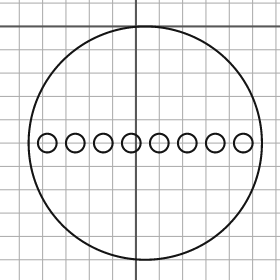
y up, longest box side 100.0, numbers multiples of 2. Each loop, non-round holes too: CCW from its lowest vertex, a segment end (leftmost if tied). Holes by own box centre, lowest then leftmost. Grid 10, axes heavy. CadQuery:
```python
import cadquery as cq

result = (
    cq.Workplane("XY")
    .moveTo(4.0, -50.0)
    .circle(50.0)
    .moveTo(-38.0, -50.0)
    .circle(4.0)
    .moveTo(-26.0, -50.0)
    .circle(4.0)
    .moveTo(-14.0, -50.0)
    .circle(4.0)
    .moveTo(-2.0, -50.0)
    .circle(4.0)
    .moveTo(10.0, -50.0)
    .circle(4.0)
    .moveTo(22.0, -50.0)
    .circle(4.0)
    .moveTo(34.0, -50.0)
    .circle(4.0)
    .moveTo(46.0, -50.0)
    .circle(4.0)
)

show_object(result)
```